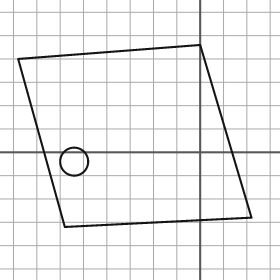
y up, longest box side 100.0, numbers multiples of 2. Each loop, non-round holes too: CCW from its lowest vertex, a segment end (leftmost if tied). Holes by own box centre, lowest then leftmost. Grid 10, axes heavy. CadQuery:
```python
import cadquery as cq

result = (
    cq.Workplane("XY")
    .moveTo(-58.0, -32.0)
    .lineTo(22.0, -28.0)
    .lineTo(0.0, 46.0)
    .lineTo(-78.0, 40.0)
    .close()
    .moveTo(-54.0, -4.0)
    .circle(6.0)
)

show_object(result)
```